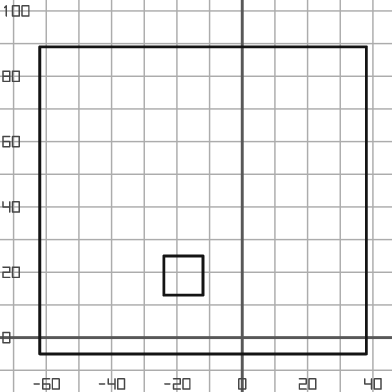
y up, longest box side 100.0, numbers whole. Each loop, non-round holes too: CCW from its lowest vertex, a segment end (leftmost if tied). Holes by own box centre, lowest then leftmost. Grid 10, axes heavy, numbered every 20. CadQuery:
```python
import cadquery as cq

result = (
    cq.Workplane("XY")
    .moveTo(-62.0, -5.0)
    .lineTo(38.0, -5.0)
    .lineTo(38.0, 89.0)
    .lineTo(-62.0, 89.0)
    .close()
    .moveTo(-24.0, 13.0)
    .lineTo(-12.0, 13.0)
    .lineTo(-12.0, 25.0)
    .lineTo(-24.0, 25.0)
    .close()
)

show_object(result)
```